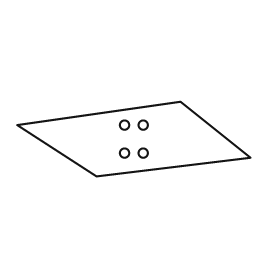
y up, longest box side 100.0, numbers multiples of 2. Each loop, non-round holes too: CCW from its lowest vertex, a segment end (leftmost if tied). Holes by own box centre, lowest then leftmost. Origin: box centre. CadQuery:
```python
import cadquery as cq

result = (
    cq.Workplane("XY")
    .moveTo(-16.0, -16.0)
    .lineTo(50.0, -8.0)
    .lineTo(20.0, 16.0)
    .lineTo(-50.0, 6.0)
    .close()
    .moveTo(-4.0, -6.0)
    .circle(2.0)
    .moveTo(4.0, -6.0)
    .circle(2.0)
    .moveTo(-4.0, 6.0)
    .circle(2.0)
    .moveTo(4.0, 6.0)
    .circle(2.0)
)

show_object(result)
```